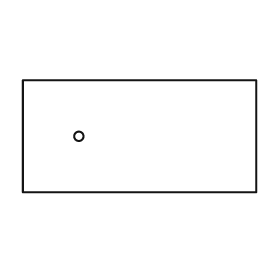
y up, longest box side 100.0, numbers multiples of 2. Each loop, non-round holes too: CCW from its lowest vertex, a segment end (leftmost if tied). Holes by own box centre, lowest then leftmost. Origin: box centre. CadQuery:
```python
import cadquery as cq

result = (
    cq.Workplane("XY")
    .moveTo(-50.0, -24.0)
    .lineTo(50.0, -24.0)
    .lineTo(50.0, 24.0)
    .lineTo(-50.0, 24.0)
    .close()
    .moveTo(-26.0, 0.0)
    .circle(2.0)
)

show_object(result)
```